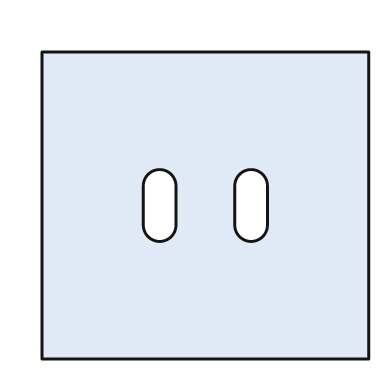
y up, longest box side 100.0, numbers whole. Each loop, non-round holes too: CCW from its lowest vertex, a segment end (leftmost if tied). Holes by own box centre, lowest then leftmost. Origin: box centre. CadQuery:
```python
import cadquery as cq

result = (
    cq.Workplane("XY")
    .moveTo(-50.0, -47.0)
    .lineTo(50.0, -47.0)
    .lineTo(50.0, 47.0)
    .lineTo(-50.0, 47.0)
    .close()
    .moveTo(-19.0, -6.0)
    .threePointArc((-14.0, -11.0), (-9.0, -6.0))
    .lineTo(-9.0, 6.0)
    .threePointArc((-14.0, 11.0), (-19.0, 6.0))
    .close()
    .moveTo(9.0, -6.0)
    .threePointArc((14.0, -11.0), (19.0, -6.0))
    .lineTo(19.0, 6.0)
    .threePointArc((14.0, 11.0), (9.0, 6.0))
    .close()
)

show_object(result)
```